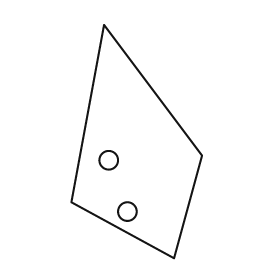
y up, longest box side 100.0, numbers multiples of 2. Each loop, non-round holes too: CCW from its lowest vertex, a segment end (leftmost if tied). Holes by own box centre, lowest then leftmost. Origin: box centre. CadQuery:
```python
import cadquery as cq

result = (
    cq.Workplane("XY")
    .moveTo(16.0, -50.0)
    .lineTo(28.0, -6.0)
    .lineTo(-14.0, 50.0)
    .lineTo(-28.0, -26.0)
    .close()
    .moveTo(-4.0, -30.0)
    .circle(4.0)
    .moveTo(-12.0, -8.0)
    .circle(4.0)
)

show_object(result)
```